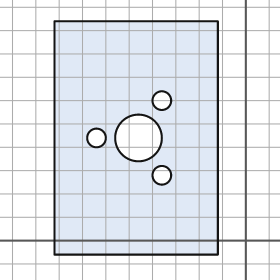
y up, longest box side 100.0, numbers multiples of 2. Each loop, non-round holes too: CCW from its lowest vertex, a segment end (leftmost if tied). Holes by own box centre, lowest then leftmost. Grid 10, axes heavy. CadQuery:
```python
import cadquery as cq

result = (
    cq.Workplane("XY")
    .moveTo(-82.0, -6.0)
    .lineTo(-12.0, -6.0)
    .lineTo(-12.0, 94.0)
    .lineTo(-82.0, 94.0)
    .close()
    .moveTo(-36.0, 28.0)
    .circle(4.0)
    .moveTo(-64.0, 44.0)
    .circle(4.0)
    .moveTo(-46.0, 44.0)
    .circle(10.0)
    .moveTo(-36.0, 60.0)
    .circle(4.0)
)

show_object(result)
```